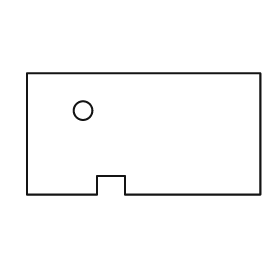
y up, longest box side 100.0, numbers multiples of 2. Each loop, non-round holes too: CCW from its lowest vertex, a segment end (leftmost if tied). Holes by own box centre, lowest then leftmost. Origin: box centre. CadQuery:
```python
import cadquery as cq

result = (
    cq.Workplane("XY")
    .moveTo(-50.0, -26.0)
    .lineTo(-20.0, -26.0)
    .lineTo(-20.0, -18.0)
    .lineTo(-8.0, -18.0)
    .lineTo(-8.0, -26.0)
    .lineTo(50.0, -26.0)
    .lineTo(50.0, 26.0)
    .lineTo(-50.0, 26.0)
    .close()
    .moveTo(-26.0, 10.0)
    .circle(4.0)
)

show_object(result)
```